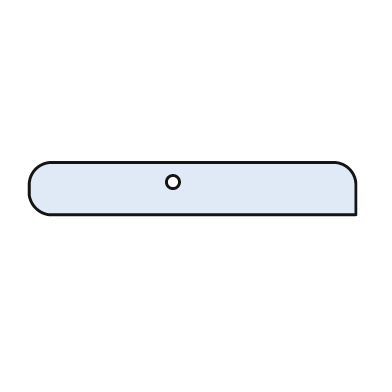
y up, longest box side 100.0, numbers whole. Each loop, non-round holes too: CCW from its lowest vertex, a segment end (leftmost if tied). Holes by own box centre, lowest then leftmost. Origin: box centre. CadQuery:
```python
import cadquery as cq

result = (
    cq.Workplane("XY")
    .moveTo(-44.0, -8.0)
    .lineTo(50.0, -8.0)
    .lineTo(50.0, 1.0)
    .threePointArc((48.0, 6.0), (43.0, 8.0))
    .lineTo(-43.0, 8.0)
    .threePointArc((-48.0, 6.0), (-50.0, 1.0))
    .lineTo(-50.0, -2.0)
    .threePointArc((-48.0, -6.0), (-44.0, -8.0))
    .close()
    .moveTo(-6.0, 2.0)
    .circle(2.0)
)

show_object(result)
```